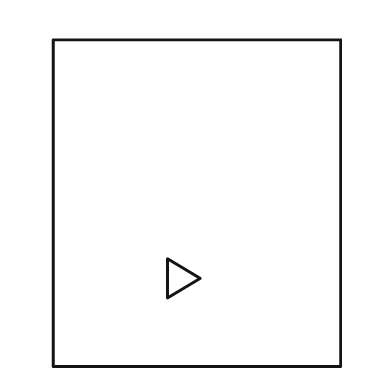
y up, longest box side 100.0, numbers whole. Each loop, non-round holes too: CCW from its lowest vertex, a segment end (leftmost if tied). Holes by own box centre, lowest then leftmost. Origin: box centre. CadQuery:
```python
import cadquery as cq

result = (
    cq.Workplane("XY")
    .moveTo(-44.0, -50.0)
    .lineTo(44.0, -50.0)
    .lineTo(44.0, 50.0)
    .lineTo(-44.0, 50.0)
    .close()
    .moveTo(-9.0, -29.0)
    .lineTo(1.0, -23.0)
    .lineTo(-9.0, -17.0)
    .close()
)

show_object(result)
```